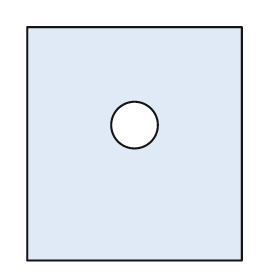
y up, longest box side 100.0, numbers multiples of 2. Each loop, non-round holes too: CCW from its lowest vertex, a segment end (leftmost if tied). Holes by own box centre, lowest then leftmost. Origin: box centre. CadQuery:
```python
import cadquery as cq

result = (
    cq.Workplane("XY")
    .moveTo(-46.0, -50.0)
    .lineTo(46.0, -50.0)
    .lineTo(46.0, 50.0)
    .lineTo(-46.0, 50.0)
    .close()
    .moveTo(0.0, 8.0)
    .circle(10.0)
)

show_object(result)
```